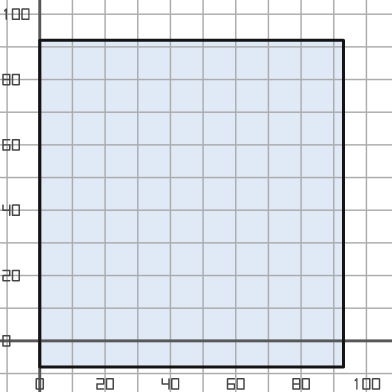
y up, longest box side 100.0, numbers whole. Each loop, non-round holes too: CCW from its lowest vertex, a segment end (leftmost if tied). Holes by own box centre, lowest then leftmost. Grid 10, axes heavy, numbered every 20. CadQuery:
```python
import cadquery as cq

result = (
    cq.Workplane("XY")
    .moveTo(0.0, -8.0)
    .lineTo(93.0, -8.0)
    .lineTo(93.0, 92.0)
    .lineTo(0.0, 92.0)
    .close()
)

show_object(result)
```